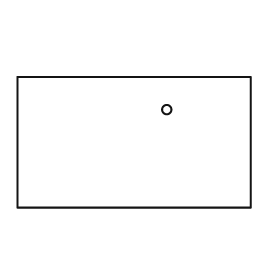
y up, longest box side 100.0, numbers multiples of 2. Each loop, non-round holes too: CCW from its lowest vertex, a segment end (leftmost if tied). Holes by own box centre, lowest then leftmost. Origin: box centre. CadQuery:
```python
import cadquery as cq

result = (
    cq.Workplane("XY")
    .moveTo(-50.0, -28.0)
    .lineTo(50.0, -28.0)
    .lineTo(50.0, 28.0)
    .lineTo(-50.0, 28.0)
    .close()
    .moveTo(14.0, 14.0)
    .circle(2.0)
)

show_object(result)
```